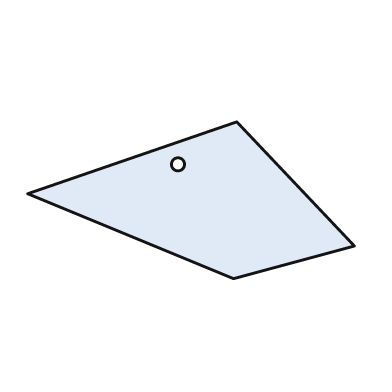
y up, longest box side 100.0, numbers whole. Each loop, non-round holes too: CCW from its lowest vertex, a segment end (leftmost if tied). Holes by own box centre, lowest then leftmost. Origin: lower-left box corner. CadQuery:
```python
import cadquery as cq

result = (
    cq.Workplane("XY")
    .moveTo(63.0, 0.0)
    .lineTo(100.0, 10.0)
    .lineTo(64.0, 48.0)
    .lineTo(0.0, 26.0)
    .close()
    .moveTo(46.0, 35.0)
    .circle(2.0)
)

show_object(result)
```